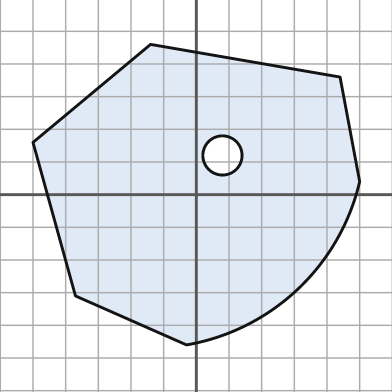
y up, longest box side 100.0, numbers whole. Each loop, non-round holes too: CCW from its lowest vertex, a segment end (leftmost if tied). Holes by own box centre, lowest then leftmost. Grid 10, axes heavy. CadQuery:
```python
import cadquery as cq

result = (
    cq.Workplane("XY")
    .moveTo(-3.0, -46.0)
    .threePointArc((31.0, -29.0), (50.0, 4.0))
    .lineTo(44.0, 36.0)
    .lineTo(-14.0, 46.0)
    .lineTo(-50.0, 16.0)
    .lineTo(-37.0, -31.0)
    .close()
    .moveTo(8.0, 12.0)
    .circle(6.0)
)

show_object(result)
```